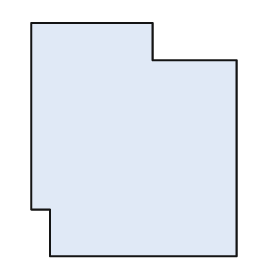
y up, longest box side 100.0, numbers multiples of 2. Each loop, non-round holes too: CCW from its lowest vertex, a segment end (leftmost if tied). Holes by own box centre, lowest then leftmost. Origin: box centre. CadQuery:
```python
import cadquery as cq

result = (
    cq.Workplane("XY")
    .moveTo(-36.0, -50.0)
    .lineTo(44.0, -50.0)
    .lineTo(44.0, 34.0)
    .lineTo(8.0, 34.0)
    .lineTo(8.0, 50.0)
    .lineTo(-44.0, 50.0)
    .lineTo(-44.0, -30.0)
    .lineTo(-36.0, -30.0)
    .close()
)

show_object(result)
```